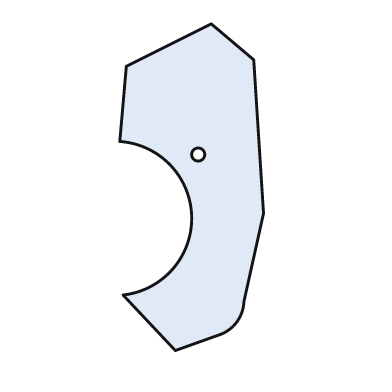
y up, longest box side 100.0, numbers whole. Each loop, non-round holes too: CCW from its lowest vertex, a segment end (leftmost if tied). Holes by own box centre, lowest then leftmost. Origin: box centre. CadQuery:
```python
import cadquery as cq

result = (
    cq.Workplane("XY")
    .moveTo(-5.0, -50.0)
    .lineTo(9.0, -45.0)
    .threePointArc((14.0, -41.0), (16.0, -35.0))
    .lineTo(22.0, -8.0)
    .lineTo(19.0, 39.0)
    .lineTo(6.0, 50.0)
    .lineTo(-20.0, 37.0)
    .lineTo(-22.0, 14.0)
    .threePointArc((0.0, -9.0), (-21.0, -33.0))
    .close()
    .moveTo(2.0, 10.0)
    .circle(2.0)
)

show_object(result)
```